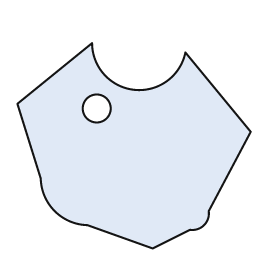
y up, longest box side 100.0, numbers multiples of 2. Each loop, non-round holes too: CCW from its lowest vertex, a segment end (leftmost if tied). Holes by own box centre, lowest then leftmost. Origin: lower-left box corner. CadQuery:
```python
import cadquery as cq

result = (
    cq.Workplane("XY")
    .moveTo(58.0, 0.0)
    .lineTo(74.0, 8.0)
    .threePointArc((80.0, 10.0), (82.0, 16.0))
    .lineTo(100.0, 50.0)
    .lineTo(72.0, 84.0)
    .threePointArc((50.0, 68.0), (32.0, 88.0))
    .lineTo(0.0, 62.0)
    .lineTo(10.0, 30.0)
    .threePointArc((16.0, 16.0), (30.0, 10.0))
    .close()
    .moveTo(34.0, 60.0)
    .circle(6.0)
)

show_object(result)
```